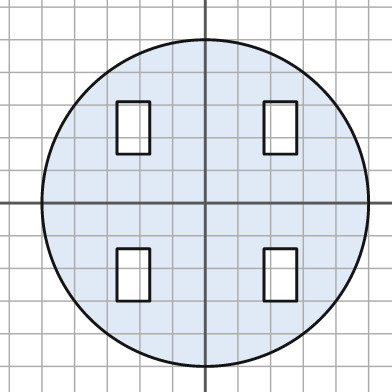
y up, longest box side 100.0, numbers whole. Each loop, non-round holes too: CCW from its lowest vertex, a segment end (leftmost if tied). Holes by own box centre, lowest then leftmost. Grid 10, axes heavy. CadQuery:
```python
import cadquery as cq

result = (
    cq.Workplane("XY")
    .moveTo(0.0, 0.0)
    .circle(50.0)
    .moveTo(-27.0, -30.0)
    .lineTo(-17.0, -30.0)
    .lineTo(-17.0, -14.0)
    .lineTo(-27.0, -14.0)
    .close()
    .moveTo(18.0, -30.0)
    .lineTo(28.0, -30.0)
    .lineTo(28.0, -14.0)
    .lineTo(18.0, -14.0)
    .close()
    .moveTo(-27.0, 15.0)
    .lineTo(-17.0, 15.0)
    .lineTo(-17.0, 31.0)
    .lineTo(-27.0, 31.0)
    .close()
    .moveTo(18.0, 15.0)
    .lineTo(28.0, 15.0)
    .lineTo(28.0, 31.0)
    .lineTo(18.0, 31.0)
    .close()
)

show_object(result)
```